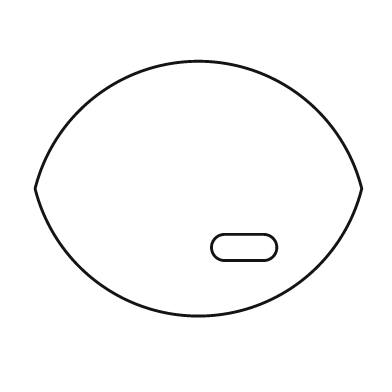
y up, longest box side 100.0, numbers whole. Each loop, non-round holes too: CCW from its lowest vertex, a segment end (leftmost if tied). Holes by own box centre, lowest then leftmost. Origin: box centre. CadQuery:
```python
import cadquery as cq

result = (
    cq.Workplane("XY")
    .moveTo(-50.0, 0.0)
    .threePointArc((0.0, -39.0), (50.0, 0.0))
    .threePointArc((0.0, 39.0), (-50.0, 0.0))
    .close()
    .moveTo(8.0, -22.0)
    .lineTo(20.0, -22.0)
    .threePointArc((24.0, -18.0), (20.0, -14.0))
    .lineTo(8.0, -14.0)
    .threePointArc((4.0, -18.0), (8.0, -22.0))
    .close()
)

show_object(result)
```